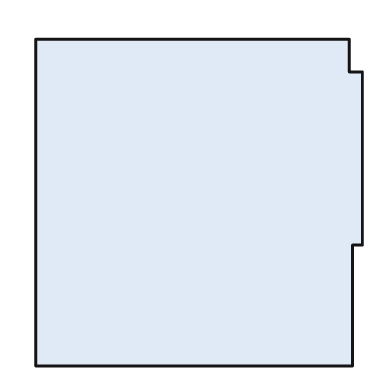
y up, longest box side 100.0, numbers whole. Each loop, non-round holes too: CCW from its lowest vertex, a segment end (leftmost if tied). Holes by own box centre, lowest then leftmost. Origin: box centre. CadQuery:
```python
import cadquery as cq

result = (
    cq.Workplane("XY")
    .moveTo(-50.0, -50.0)
    .lineTo(47.0, -50.0)
    .lineTo(47.0, -13.0)
    .lineTo(50.0, -13.0)
    .lineTo(50.0, 40.0)
    .lineTo(46.0, 40.0)
    .lineTo(46.0, 50.0)
    .lineTo(-50.0, 50.0)
    .close()
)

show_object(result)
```